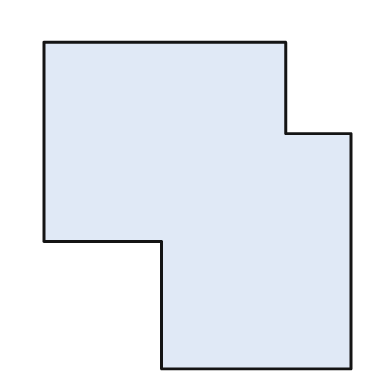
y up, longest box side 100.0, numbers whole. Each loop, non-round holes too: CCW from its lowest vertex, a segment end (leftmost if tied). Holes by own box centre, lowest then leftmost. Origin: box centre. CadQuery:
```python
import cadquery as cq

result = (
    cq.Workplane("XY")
    .moveTo(-11.0, -50.0)
    .lineTo(47.0, -50.0)
    .lineTo(47.0, 22.0)
    .lineTo(27.0, 22.0)
    .lineTo(27.0, 50.0)
    .lineTo(-47.0, 50.0)
    .lineTo(-47.0, -11.0)
    .lineTo(-11.0, -11.0)
    .close()
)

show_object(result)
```